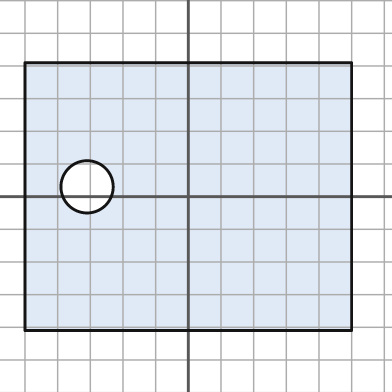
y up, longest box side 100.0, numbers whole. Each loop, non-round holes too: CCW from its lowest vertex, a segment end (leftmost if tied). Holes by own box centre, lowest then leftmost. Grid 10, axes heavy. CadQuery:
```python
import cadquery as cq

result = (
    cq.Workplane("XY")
    .moveTo(-50.0, -41.0)
    .lineTo(50.0, -41.0)
    .lineTo(50.0, 41.0)
    .lineTo(-50.0, 41.0)
    .close()
    .moveTo(-31.0, 3.0)
    .circle(8.0)
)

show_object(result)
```